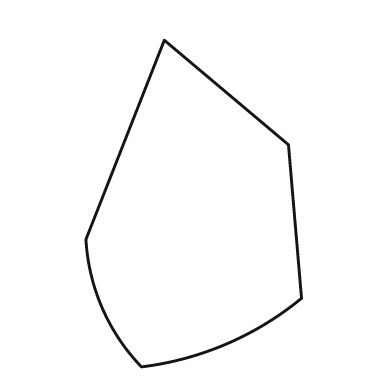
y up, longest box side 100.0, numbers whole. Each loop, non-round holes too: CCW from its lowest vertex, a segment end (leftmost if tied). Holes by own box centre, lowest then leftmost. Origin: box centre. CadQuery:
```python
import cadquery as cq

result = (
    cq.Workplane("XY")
    .moveTo(-16.0, -50.0)
    .threePointArc((10.0, -43.0), (33.0, -29.0))
    .lineTo(29.0, 18.0)
    .lineTo(-9.0, 50.0)
    .lineTo(-33.0, -11.0)
    .threePointArc((-28.0, -32.0), (-16.0, -50.0))
    .close()
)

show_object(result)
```